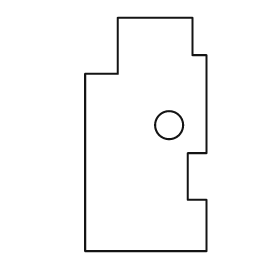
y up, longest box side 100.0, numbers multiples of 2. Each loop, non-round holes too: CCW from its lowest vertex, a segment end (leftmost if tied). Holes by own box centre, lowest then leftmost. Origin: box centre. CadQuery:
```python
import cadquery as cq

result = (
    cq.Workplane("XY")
    .moveTo(-26.0, -50.0)
    .lineTo(26.0, -50.0)
    .lineTo(26.0, -28.0)
    .lineTo(18.0, -28.0)
    .lineTo(18.0, -8.0)
    .lineTo(26.0, -8.0)
    .lineTo(26.0, 34.0)
    .lineTo(20.0, 34.0)
    .lineTo(20.0, 50.0)
    .lineTo(-12.0, 50.0)
    .lineTo(-12.0, 26.0)
    .lineTo(-26.0, 26.0)
    .close()
    .moveTo(10.0, 4.0)
    .circle(6.0)
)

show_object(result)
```